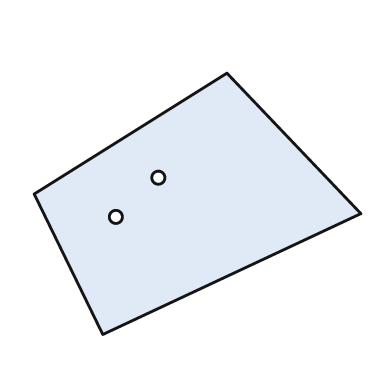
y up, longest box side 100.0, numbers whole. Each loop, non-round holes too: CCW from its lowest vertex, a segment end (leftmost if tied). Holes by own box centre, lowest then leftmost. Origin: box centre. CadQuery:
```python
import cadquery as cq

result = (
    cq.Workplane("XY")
    .moveTo(-29.0, -40.0)
    .lineTo(50.0, -3.0)
    .lineTo(9.0, 40.0)
    .lineTo(-50.0, 3.0)
    .close()
    .moveTo(-25.0, -4.0)
    .circle(2.0)
    .moveTo(-12.0, 8.0)
    .circle(2.0)
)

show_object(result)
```